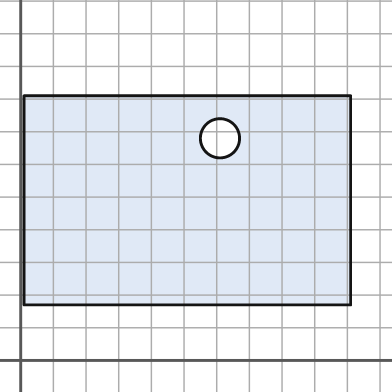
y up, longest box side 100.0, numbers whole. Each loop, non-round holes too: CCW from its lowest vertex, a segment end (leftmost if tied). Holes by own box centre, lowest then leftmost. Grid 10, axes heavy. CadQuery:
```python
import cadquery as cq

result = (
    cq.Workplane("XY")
    .moveTo(1.0, 17.0)
    .lineTo(101.0, 17.0)
    .lineTo(101.0, 81.0)
    .lineTo(1.0, 81.0)
    .close()
    .moveTo(61.0, 68.0)
    .circle(6.0)
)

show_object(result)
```